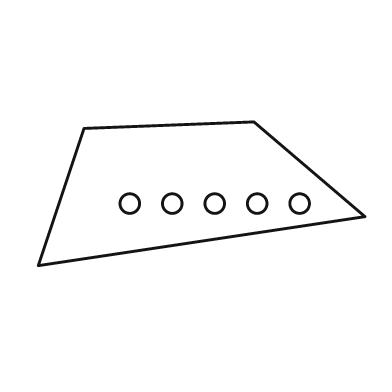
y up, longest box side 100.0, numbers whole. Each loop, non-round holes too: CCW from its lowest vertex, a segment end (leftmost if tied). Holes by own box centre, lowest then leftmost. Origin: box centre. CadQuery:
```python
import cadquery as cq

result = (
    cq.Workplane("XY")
    .moveTo(-50.0, -22.0)
    .lineTo(50.0, -7.0)
    .lineTo(16.0, 22.0)
    .lineTo(-36.0, 20.0)
    .close()
    .moveTo(-22.0, -3.0)
    .circle(3.0)
    .moveTo(-9.0, -3.0)
    .circle(3.0)
    .moveTo(4.0, -3.0)
    .circle(3.0)
    .moveTo(17.0, -3.0)
    .circle(3.0)
    .moveTo(30.0, -3.0)
    .circle(3.0)
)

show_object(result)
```